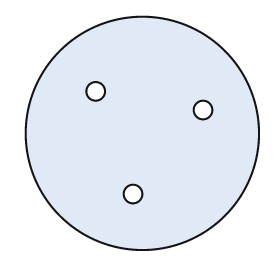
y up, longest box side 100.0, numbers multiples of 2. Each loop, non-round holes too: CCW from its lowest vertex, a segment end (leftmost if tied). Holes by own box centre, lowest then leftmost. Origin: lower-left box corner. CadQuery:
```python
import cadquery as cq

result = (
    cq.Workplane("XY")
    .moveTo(50.0, 50.0)
    .circle(50.0)
    .moveTo(46.0, 24.0)
    .circle(4.0)
    .moveTo(76.0, 60.0)
    .circle(4.0)
    .moveTo(30.0, 68.0)
    .circle(4.0)
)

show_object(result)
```